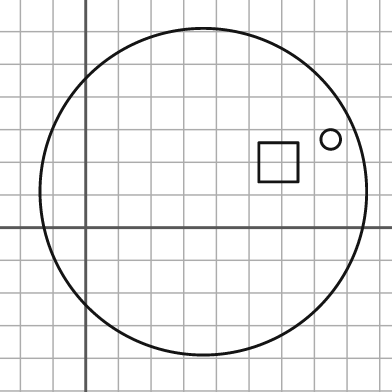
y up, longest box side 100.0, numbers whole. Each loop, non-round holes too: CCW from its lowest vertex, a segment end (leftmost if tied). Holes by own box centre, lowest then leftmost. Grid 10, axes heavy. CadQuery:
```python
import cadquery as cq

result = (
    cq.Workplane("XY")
    .moveTo(36.0, 11.0)
    .circle(50.0)
    .moveTo(53.0, 14.0)
    .lineTo(65.0, 14.0)
    .lineTo(65.0, 26.0)
    .lineTo(53.0, 26.0)
    .close()
    .moveTo(75.0, 27.0)
    .circle(3.0)
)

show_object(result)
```